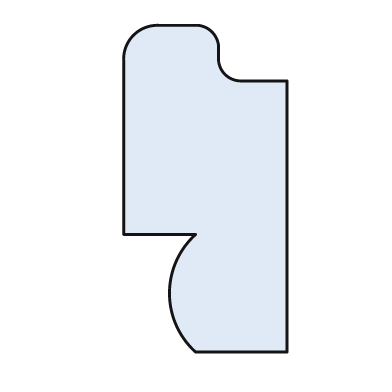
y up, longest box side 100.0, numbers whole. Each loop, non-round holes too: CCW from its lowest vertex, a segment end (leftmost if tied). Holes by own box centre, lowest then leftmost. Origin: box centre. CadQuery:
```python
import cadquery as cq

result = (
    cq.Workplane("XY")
    .moveTo(-3.0, -50.0)
    .lineTo(25.0, -50.0)
    .lineTo(25.0, 33.0)
    .lineTo(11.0, 33.0)
    .threePointArc((6.0, 35.0), (4.0, 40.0))
    .lineTo(4.0, 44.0)
    .threePointArc((2.0, 48.0), (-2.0, 50.0))
    .lineTo(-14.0, 50.0)
    .threePointArc((-22.0, 47.0), (-25.0, 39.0))
    .lineTo(-25.0, -14.0)
    .lineTo(-3.0, -14.0)
    .threePointArc((-11.0, -32.0), (-3.0, -50.0))
    .close()
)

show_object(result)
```